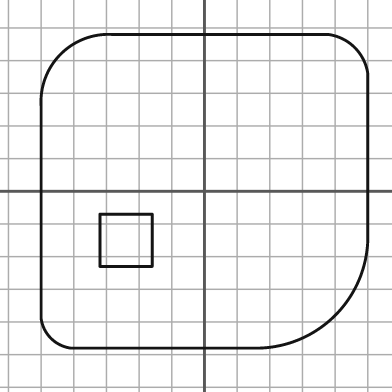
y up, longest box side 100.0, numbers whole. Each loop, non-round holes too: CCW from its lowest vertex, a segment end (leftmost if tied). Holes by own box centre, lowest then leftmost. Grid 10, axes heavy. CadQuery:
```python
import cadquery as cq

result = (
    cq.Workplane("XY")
    .moveTo(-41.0, -48.0)
    .lineTo(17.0, -48.0)
    .threePointArc((40.0, -38.0), (50.0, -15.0))
    .lineTo(50.0, 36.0)
    .threePointArc((46.0, 44.0), (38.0, 48.0))
    .lineTo(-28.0, 48.0)
    .threePointArc((-44.0, 42.0), (-50.0, 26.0))
    .lineTo(-50.0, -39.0)
    .threePointArc((-47.0, -45.0), (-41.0, -48.0))
    .close()
    .moveTo(-32.0, -23.0)
    .lineTo(-16.0, -23.0)
    .lineTo(-16.0, -7.0)
    .lineTo(-32.0, -7.0)
    .close()
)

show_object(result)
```